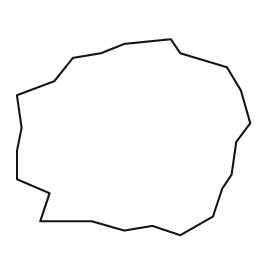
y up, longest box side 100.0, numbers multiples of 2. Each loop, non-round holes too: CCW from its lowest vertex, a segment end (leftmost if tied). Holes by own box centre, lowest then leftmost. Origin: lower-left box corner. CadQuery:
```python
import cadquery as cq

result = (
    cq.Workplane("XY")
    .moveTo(70.0, 0.0)
    .lineTo(84.0, 8.0)
    .lineTo(88.0, 20.0)
    .lineTo(92.0, 26.0)
    .lineTo(94.0, 40.0)
    .lineTo(100.0, 48.0)
    .lineTo(96.0, 62.0)
    .lineTo(90.0, 72.0)
    .lineTo(70.0, 78.0)
    .lineTo(66.0, 84.0)
    .lineTo(46.0, 82.0)
    .lineTo(36.0, 78.0)
    .lineTo(24.0, 76.0)
    .lineTo(16.0, 66.0)
    .lineTo(0.0, 60.0)
    .lineTo(2.0, 46.0)
    .lineTo(0.0, 36.0)
    .lineTo(0.0, 24.0)
    .lineTo(14.0, 18.0)
    .lineTo(10.0, 6.0)
    .lineTo(32.0, 6.0)
    .lineTo(46.0, 2.0)
    .lineTo(58.0, 4.0)
    .close()
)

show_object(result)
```